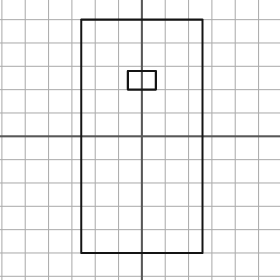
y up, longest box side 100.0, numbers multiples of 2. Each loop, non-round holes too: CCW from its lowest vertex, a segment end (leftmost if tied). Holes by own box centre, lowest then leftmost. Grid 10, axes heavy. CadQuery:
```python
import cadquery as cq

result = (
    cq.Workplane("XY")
    .moveTo(-26.0, -50.0)
    .lineTo(26.0, -50.0)
    .lineTo(26.0, 50.0)
    .lineTo(-26.0, 50.0)
    .close()
    .moveTo(-6.0, 20.0)
    .lineTo(6.0, 20.0)
    .lineTo(6.0, 28.0)
    .lineTo(-6.0, 28.0)
    .close()
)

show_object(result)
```